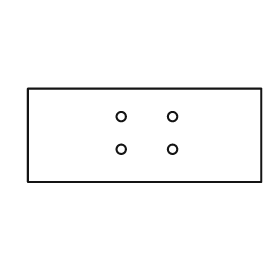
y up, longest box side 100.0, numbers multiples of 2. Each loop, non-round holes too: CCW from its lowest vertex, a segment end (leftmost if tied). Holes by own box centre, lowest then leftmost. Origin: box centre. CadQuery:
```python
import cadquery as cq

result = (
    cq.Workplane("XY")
    .moveTo(-50.0, -20.0)
    .lineTo(50.0, -20.0)
    .lineTo(50.0, 20.0)
    .lineTo(-50.0, 20.0)
    .close()
    .moveTo(-10.0, -6.0)
    .circle(2.0)
    .moveTo(12.0, -6.0)
    .circle(2.0)
    .moveTo(-10.0, 8.0)
    .circle(2.0)
    .moveTo(12.0, 8.0)
    .circle(2.0)
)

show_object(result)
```